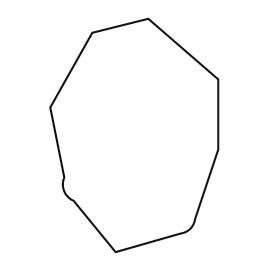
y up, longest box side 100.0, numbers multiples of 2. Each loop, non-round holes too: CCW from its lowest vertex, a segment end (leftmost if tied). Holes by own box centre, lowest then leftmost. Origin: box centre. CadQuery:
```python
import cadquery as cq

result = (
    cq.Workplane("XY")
    .moveTo(-8.0, -50.0)
    .lineTo(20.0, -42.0)
    .threePointArc((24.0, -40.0), (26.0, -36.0))
    .lineTo(36.0, -6.0)
    .lineTo(36.0, 24.0)
    .lineTo(6.0, 50.0)
    .lineTo(-18.0, 44.0)
    .lineTo(-36.0, 12.0)
    .lineTo(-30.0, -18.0)
    .threePointArc((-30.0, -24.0), (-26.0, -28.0))
    .close()
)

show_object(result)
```